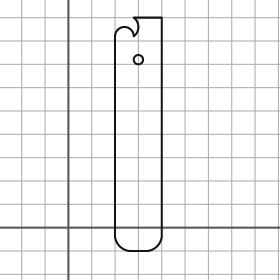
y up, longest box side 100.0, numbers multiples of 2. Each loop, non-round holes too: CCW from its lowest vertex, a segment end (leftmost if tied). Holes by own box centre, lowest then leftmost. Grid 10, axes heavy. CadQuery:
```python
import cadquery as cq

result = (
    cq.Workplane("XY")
    .moveTo(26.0, -10.0)
    .lineTo(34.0, -10.0)
    .threePointArc((38.0, -8.0), (40.0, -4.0))
    .lineTo(40.0, 90.0)
    .lineTo(28.0, 90.0)
    .threePointArc((30.0, 86.0), (28.0, 82.0))
    .threePointArc((24.0, 86.0), (20.0, 82.0))
    .lineTo(20.0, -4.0)
    .threePointArc((22.0, -8.0), (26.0, -10.0))
    .close()
    .moveTo(30.0, 72.0)
    .circle(2.0)
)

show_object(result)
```